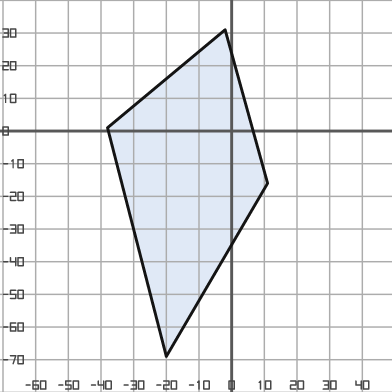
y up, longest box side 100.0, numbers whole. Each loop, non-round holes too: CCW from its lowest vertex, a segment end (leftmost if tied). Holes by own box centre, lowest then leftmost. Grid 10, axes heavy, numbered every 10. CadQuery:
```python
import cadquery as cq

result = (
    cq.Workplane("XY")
    .moveTo(-20.0, -69.0)
    .lineTo(11.0, -16.0)
    .lineTo(-2.0, 31.0)
    .lineTo(-38.0, 1.0)
    .close()
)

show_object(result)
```